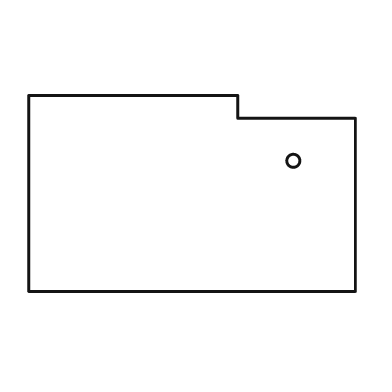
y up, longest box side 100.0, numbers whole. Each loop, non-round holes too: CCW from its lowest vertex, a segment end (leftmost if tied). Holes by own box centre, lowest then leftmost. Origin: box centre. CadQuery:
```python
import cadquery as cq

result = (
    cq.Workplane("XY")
    .moveTo(-50.0, -30.0)
    .lineTo(50.0, -30.0)
    .lineTo(50.0, 23.0)
    .lineTo(14.0, 23.0)
    .lineTo(14.0, 30.0)
    .lineTo(-50.0, 30.0)
    .close()
    .moveTo(31.0, 10.0)
    .circle(2.0)
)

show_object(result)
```